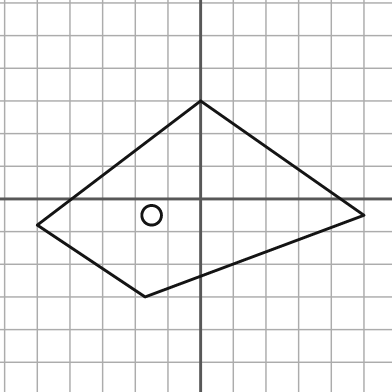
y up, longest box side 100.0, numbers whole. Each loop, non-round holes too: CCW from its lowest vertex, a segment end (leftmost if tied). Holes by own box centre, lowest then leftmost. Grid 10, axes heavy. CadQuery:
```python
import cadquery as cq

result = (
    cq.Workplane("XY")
    .moveTo(-17.0, -30.0)
    .lineTo(50.0, -5.0)
    .lineTo(0.0, 30.0)
    .lineTo(-50.0, -8.0)
    .close()
    .moveTo(-15.0, -5.0)
    .circle(3.0)
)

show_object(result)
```